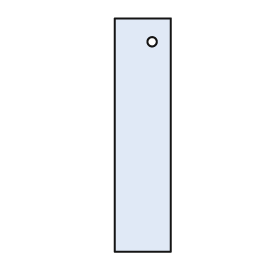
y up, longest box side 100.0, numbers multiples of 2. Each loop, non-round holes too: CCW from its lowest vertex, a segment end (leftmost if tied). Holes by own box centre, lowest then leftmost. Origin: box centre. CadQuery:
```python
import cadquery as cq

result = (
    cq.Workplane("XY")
    .moveTo(-12.0, -50.0)
    .lineTo(12.0, -50.0)
    .lineTo(12.0, 50.0)
    .lineTo(-12.0, 50.0)
    .close()
    .moveTo(4.0, 40.0)
    .circle(2.0)
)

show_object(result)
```